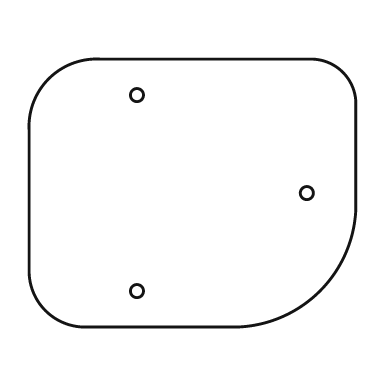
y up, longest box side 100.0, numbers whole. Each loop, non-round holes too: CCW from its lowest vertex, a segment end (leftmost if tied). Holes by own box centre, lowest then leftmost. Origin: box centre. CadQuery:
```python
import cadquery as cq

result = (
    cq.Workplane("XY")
    .moveTo(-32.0, -41.0)
    .lineTo(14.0, -41.0)
    .threePointArc((39.0, -30.0), (50.0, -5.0))
    .lineTo(50.0, 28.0)
    .threePointArc((46.0, 37.0), (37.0, 41.0))
    .lineTo(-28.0, 41.0)
    .threePointArc((-44.0, 35.0), (-50.0, 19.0))
    .lineTo(-50.0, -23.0)
    .threePointArc((-45.0, -36.0), (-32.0, -41.0))
    .close()
    .moveTo(-17.0, -30.0)
    .circle(2.0)
    .moveTo(35.0, 0.0)
    .circle(2.0)
    .moveTo(-17.0, 30.0)
    .circle(2.0)
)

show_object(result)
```